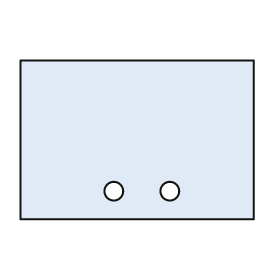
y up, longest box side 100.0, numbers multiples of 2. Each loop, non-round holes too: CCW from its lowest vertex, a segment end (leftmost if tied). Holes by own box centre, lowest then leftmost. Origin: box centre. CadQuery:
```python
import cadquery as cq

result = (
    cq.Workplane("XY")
    .moveTo(-50.0, -34.0)
    .lineTo(50.0, -34.0)
    .lineTo(50.0, 34.0)
    .lineTo(-50.0, 34.0)
    .close()
    .moveTo(-10.0, -22.0)
    .circle(4.0)
    .moveTo(14.0, -22.0)
    .circle(4.0)
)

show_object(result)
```